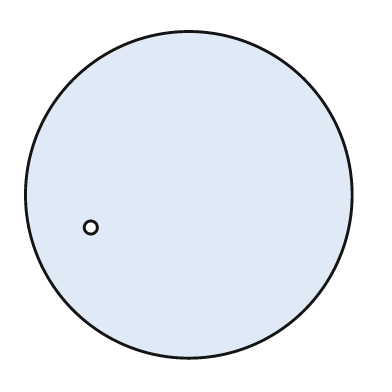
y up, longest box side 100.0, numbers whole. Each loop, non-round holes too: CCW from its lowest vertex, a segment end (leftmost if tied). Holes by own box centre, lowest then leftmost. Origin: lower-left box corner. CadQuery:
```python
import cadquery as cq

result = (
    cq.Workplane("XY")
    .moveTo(50.0, 50.0)
    .circle(50.0)
    .moveTo(20.0, 40.0)
    .circle(2.0)
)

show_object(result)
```